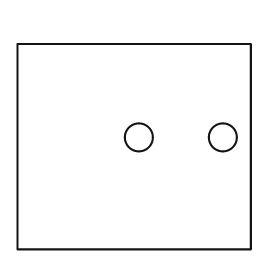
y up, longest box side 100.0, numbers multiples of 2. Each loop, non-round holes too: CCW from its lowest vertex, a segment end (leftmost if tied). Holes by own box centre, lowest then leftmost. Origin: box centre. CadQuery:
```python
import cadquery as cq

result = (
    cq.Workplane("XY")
    .moveTo(-50.0, -44.0)
    .lineTo(50.0, -44.0)
    .lineTo(50.0, 44.0)
    .lineTo(-50.0, 44.0)
    .close()
    .moveTo(2.0, 4.0)
    .circle(6.0)
    .moveTo(38.0, 4.0)
    .circle(6.0)
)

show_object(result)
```